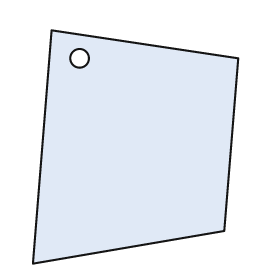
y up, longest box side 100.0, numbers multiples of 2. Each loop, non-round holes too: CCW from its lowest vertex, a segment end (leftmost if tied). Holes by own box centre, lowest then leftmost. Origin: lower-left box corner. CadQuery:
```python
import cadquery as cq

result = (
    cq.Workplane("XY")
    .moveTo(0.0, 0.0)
    .lineTo(82.0, 14.0)
    .lineTo(88.0, 88.0)
    .lineTo(8.0, 100.0)
    .close()
    .moveTo(20.0, 88.0)
    .circle(4.0)
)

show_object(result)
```